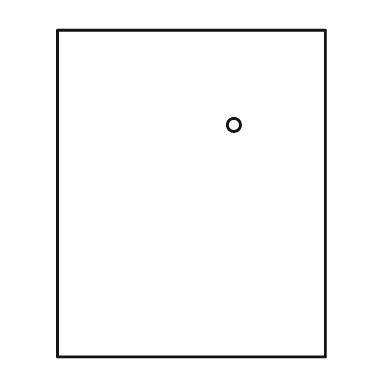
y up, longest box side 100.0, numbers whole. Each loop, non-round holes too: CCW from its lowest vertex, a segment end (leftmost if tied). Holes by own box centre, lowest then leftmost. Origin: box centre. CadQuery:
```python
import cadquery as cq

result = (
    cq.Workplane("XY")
    .moveTo(-41.0, -50.0)
    .lineTo(41.0, -50.0)
    .lineTo(41.0, 50.0)
    .lineTo(-41.0, 50.0)
    .close()
    .moveTo(13.0, 21.0)
    .circle(2.0)
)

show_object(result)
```